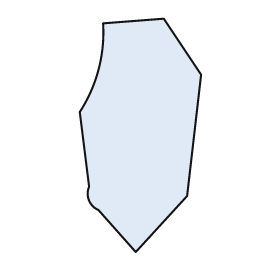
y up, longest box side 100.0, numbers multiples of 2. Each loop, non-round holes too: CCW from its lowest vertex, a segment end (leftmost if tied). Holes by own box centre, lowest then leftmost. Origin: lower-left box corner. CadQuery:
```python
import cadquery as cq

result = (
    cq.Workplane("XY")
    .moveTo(24.0, 0.0)
    .lineTo(46.0, 24.0)
    .lineTo(52.0, 76.0)
    .lineTo(36.0, 100.0)
    .lineTo(10.0, 98.0)
    .threePointArc((8.0, 78.0), (0.0, 60.0))
    .lineTo(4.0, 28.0)
    .threePointArc((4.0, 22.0), (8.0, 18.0))
    .close()
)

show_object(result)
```